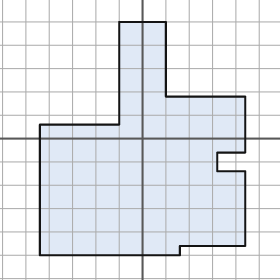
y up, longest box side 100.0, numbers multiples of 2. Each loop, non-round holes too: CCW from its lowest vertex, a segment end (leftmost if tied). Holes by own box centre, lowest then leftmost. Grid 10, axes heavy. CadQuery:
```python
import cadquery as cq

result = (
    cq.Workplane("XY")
    .moveTo(-44.0, -50.0)
    .lineTo(16.0, -50.0)
    .lineTo(16.0, -46.0)
    .lineTo(44.0, -46.0)
    .lineTo(44.0, -14.0)
    .lineTo(32.0, -14.0)
    .lineTo(32.0, -6.0)
    .lineTo(44.0, -6.0)
    .lineTo(44.0, 18.0)
    .lineTo(10.0, 18.0)
    .lineTo(10.0, 50.0)
    .lineTo(-10.0, 50.0)
    .lineTo(-10.0, 6.0)
    .lineTo(-44.0, 6.0)
    .close()
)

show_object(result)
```